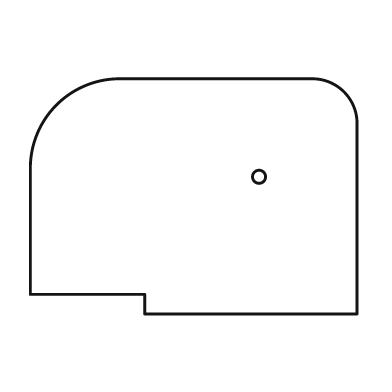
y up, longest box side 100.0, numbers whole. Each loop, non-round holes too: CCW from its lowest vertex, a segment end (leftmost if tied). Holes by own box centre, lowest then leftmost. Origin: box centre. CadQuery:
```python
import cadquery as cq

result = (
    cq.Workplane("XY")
    .moveTo(-15.0, -36.0)
    .lineTo(50.0, -36.0)
    .lineTo(50.0, 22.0)
    .threePointArc((46.0, 32.0), (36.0, 36.0))
    .lineTo(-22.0, 36.0)
    .threePointArc((-42.0, 28.0), (-50.0, 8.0))
    .lineTo(-50.0, -30.0)
    .lineTo(-15.0, -30.0)
    .close()
    .moveTo(20.0, 6.0)
    .circle(2.0)
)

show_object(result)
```